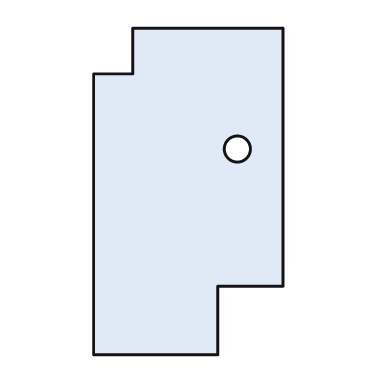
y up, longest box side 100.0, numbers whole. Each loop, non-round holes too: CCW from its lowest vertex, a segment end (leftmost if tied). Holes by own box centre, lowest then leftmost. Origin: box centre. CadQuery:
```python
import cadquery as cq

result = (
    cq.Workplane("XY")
    .moveTo(-29.0, -50.0)
    .lineTo(9.0, -50.0)
    .lineTo(9.0, -29.0)
    .lineTo(29.0, -29.0)
    .lineTo(29.0, 50.0)
    .lineTo(-17.0, 50.0)
    .lineTo(-17.0, 36.0)
    .lineTo(-29.0, 36.0)
    .close()
    .moveTo(15.0, 13.0)
    .circle(4.0)
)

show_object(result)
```